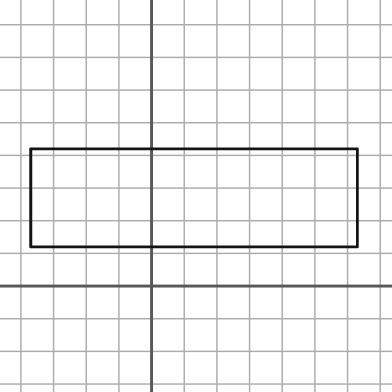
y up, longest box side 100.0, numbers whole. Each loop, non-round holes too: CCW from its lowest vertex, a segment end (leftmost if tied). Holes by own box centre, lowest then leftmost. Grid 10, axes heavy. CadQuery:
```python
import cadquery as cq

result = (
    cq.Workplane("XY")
    .moveTo(-37.0, 12.0)
    .lineTo(63.0, 12.0)
    .lineTo(63.0, 42.0)
    .lineTo(-37.0, 42.0)
    .close()
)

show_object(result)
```